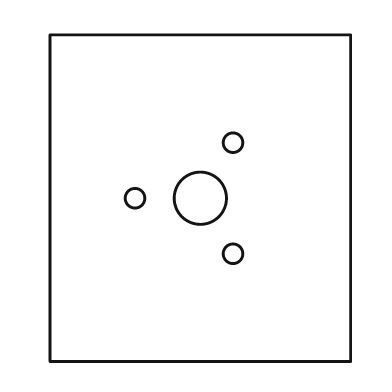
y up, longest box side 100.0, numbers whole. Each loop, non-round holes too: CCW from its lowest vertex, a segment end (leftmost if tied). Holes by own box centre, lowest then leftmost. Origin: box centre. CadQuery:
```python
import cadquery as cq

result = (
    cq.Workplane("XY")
    .moveTo(-46.0, -50.0)
    .lineTo(46.0, -50.0)
    .lineTo(46.0, 50.0)
    .lineTo(-46.0, 50.0)
    .close()
    .moveTo(10.0, -17.0)
    .circle(3.0)
    .moveTo(-20.0, 0.0)
    .circle(3.0)
    .moveTo(0.0, 0.0)
    .circle(8.0)
    .moveTo(10.0, 17.0)
    .circle(3.0)
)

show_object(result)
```